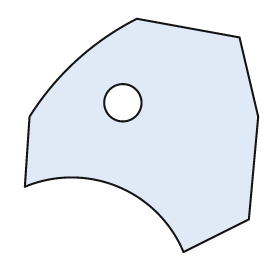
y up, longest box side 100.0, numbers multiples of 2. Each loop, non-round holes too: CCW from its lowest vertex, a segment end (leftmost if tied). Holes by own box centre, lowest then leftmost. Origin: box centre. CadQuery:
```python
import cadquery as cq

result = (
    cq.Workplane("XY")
    .moveTo(18.0, -50.0)
    .lineTo(46.0, -36.0)
    .lineTo(50.0, 8.0)
    .lineTo(42.0, 42.0)
    .lineTo(-2.0, 50.0)
    .threePointArc((-28.0, 32.0), (-48.0, 8.0))
    .lineTo(-50.0, -22.0)
    .threePointArc((-10.0, -22.0), (18.0, -50.0))
    .close()
    .moveTo(-8.0, 14.0)
    .circle(8.0)
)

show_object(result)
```